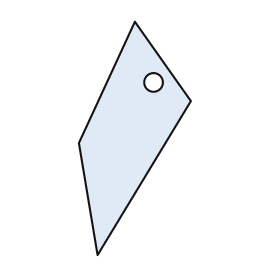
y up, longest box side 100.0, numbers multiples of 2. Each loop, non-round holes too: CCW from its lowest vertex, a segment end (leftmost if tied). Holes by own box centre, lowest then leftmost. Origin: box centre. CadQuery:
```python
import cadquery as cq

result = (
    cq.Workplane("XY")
    .moveTo(-16.0, -50.0)
    .lineTo(24.0, 16.0)
    .lineTo(0.0, 50.0)
    .lineTo(-24.0, -2.0)
    .close()
    .moveTo(8.0, 24.0)
    .circle(4.0)
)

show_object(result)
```